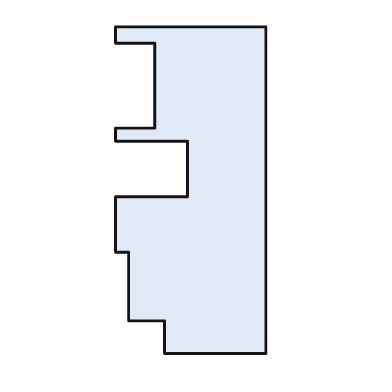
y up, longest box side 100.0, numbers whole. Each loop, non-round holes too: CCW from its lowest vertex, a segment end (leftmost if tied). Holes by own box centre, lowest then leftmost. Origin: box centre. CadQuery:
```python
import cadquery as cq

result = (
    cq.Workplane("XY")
    .moveTo(-8.0, -50.0)
    .lineTo(23.0, -50.0)
    .lineTo(23.0, 50.0)
    .lineTo(-23.0, 50.0)
    .lineTo(-23.0, 45.0)
    .lineTo(-11.0, 45.0)
    .lineTo(-11.0, 19.0)
    .lineTo(-23.0, 19.0)
    .lineTo(-23.0, 15.0)
    .lineTo(-1.0, 15.0)
    .lineTo(-1.0, -2.0)
    .lineTo(-23.0, -2.0)
    .lineTo(-23.0, -19.0)
    .lineTo(-19.0, -19.0)
    .lineTo(-19.0, -40.0)
    .lineTo(-8.0, -40.0)
    .close()
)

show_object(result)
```